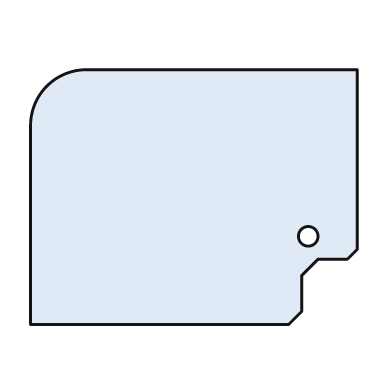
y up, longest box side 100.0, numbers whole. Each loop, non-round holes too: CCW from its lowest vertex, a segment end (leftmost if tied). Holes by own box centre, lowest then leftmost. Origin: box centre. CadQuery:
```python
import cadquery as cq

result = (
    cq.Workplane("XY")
    .moveTo(-50.0, -39.0)
    .lineTo(29.0, -39.0)
    .lineTo(33.0, -35.0)
    .lineTo(33.0, -24.0)
    .lineTo(38.0, -19.0)
    .lineTo(47.0, -19.0)
    .lineTo(50.0, -16.0)
    .lineTo(50.0, 39.0)
    .lineTo(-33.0, 39.0)
    .threePointArc((-45.0, 34.0), (-50.0, 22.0))
    .close()
    .moveTo(35.0, -12.0)
    .circle(3.0)
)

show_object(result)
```